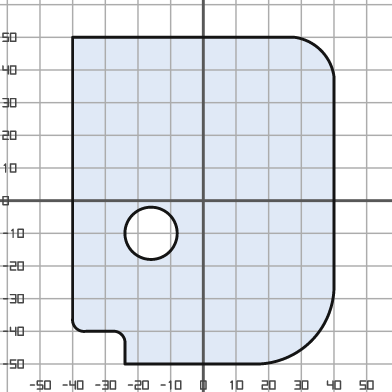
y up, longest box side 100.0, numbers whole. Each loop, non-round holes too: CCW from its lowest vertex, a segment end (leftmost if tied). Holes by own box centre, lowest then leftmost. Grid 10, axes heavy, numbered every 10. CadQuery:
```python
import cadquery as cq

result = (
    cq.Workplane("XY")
    .moveTo(-24.0, -50.0)
    .lineTo(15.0, -50.0)
    .threePointArc((33.0, -43.0), (40.0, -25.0))
    .lineTo(40.0, 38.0)
    .threePointArc((36.0, 46.0), (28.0, 50.0))
    .lineTo(-40.0, 50.0)
    .lineTo(-40.0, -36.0)
    .threePointArc((-39.0, -39.0), (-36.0, -40.0))
    .lineTo(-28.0, -40.0)
    .threePointArc((-25.0, -41.0), (-24.0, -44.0))
    .close()
    .moveTo(-16.0, -10.0)
    .circle(8.0)
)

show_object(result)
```